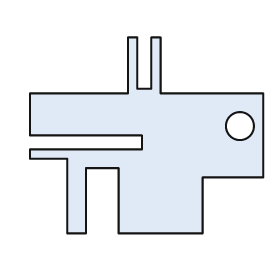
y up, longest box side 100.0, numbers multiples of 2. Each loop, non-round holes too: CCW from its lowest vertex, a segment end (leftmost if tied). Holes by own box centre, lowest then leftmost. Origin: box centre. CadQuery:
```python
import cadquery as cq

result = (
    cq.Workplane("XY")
    .moveTo(-34.0, -42.0)
    .lineTo(-26.0, -42.0)
    .lineTo(-26.0, -14.0)
    .lineTo(-12.0, -14.0)
    .lineTo(-12.0, -42.0)
    .lineTo(24.0, -42.0)
    .lineTo(24.0, -18.0)
    .lineTo(50.0, -18.0)
    .lineTo(50.0, 18.0)
    .lineTo(6.0, 18.0)
    .lineTo(6.0, 42.0)
    .lineTo(2.0, 42.0)
    .lineTo(2.0, 20.0)
    .lineTo(-4.0, 20.0)
    .lineTo(-4.0, 42.0)
    .lineTo(-8.0, 42.0)
    .lineTo(-8.0, 18.0)
    .lineTo(-50.0, 18.0)
    .lineTo(-50.0, 0.0)
    .lineTo(-2.0, 0.0)
    .lineTo(-2.0, -6.0)
    .lineTo(-50.0, -6.0)
    .lineTo(-50.0, -10.0)
    .lineTo(-34.0, -10.0)
    .close()
    .moveTo(40.0, 4.0)
    .circle(6.0)
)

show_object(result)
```